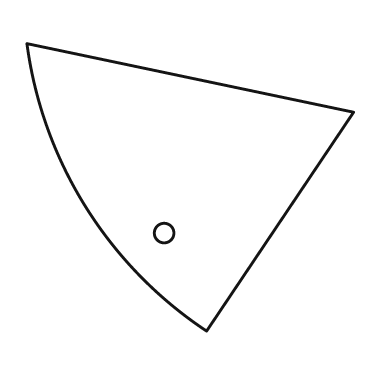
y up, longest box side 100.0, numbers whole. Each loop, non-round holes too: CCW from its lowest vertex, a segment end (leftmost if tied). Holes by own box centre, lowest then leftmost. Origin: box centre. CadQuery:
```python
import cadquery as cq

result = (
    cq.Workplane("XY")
    .moveTo(5.0, -44.0)
    .lineTo(50.0, 23.0)
    .lineTo(-50.0, 44.0)
    .threePointArc((-32.0, -6.0), (5.0, -44.0))
    .close()
    .moveTo(-8.0, -14.0)
    .circle(3.0)
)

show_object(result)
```